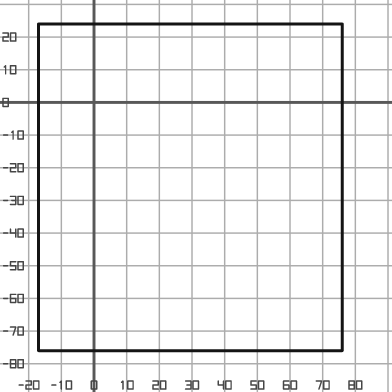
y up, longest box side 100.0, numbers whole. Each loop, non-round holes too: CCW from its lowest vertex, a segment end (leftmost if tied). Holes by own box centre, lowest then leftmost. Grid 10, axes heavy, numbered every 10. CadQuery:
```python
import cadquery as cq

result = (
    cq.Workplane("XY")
    .moveTo(-17.0, -76.0)
    .lineTo(76.0, -76.0)
    .lineTo(76.0, 24.0)
    .lineTo(-17.0, 24.0)
    .close()
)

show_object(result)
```